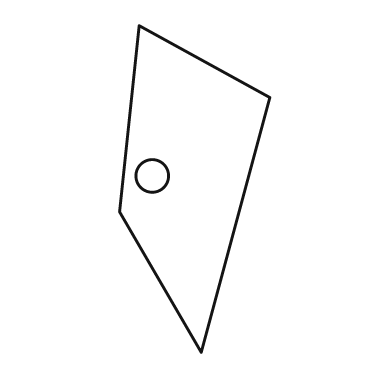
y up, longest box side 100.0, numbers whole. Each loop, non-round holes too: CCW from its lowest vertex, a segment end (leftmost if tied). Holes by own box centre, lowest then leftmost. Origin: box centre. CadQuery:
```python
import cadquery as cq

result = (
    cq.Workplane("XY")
    .moveTo(2.0, -50.0)
    .lineTo(23.0, 28.0)
    .lineTo(-17.0, 50.0)
    .lineTo(-23.0, -7.0)
    .close()
    .moveTo(-13.0, 4.0)
    .circle(5.0)
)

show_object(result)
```